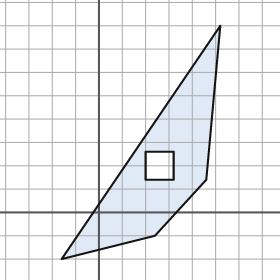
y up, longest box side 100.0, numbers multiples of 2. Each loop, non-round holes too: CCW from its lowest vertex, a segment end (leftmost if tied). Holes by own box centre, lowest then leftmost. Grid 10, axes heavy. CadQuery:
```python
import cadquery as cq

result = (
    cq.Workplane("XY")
    .moveTo(-16.0, -20.0)
    .lineTo(24.0, -10.0)
    .lineTo(46.0, 14.0)
    .lineTo(52.0, 80.0)
    .close()
    .moveTo(20.0, 14.0)
    .lineTo(32.0, 14.0)
    .lineTo(32.0, 26.0)
    .lineTo(20.0, 26.0)
    .close()
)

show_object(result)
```